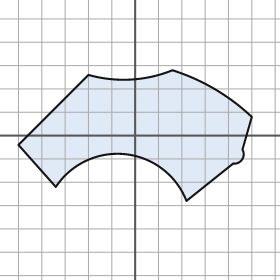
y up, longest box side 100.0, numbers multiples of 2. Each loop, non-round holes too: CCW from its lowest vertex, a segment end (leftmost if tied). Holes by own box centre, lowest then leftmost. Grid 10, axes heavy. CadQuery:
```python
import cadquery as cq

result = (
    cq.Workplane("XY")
    .moveTo(22.0, -28.0)
    .lineTo(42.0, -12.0)
    .threePointArc((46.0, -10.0), (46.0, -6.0))
    .lineTo(50.0, 8.0)
    .threePointArc((34.0, 20.0), (16.0, 28.0))
    .threePointArc((-2.0, 24.0), (-20.0, 26.0))
    .lineTo(-50.0, -4.0)
    .lineTo(-34.0, -22.0)
    .threePointArc((-4.0, -8.0), (22.0, -28.0))
    .close()
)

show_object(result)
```